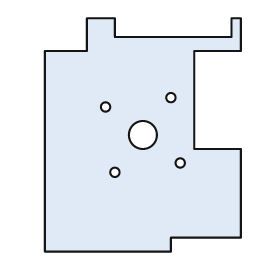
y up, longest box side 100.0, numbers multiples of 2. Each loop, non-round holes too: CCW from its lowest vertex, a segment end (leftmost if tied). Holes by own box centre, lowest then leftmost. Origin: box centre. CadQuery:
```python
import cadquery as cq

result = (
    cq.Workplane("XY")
    .moveTo(-42.0, -50.0)
    .lineTo(12.0, -50.0)
    .lineTo(12.0, -44.0)
    .lineTo(42.0, -44.0)
    .lineTo(42.0, -6.0)
    .lineTo(22.0, -6.0)
    .lineTo(22.0, 36.0)
    .lineTo(42.0, 36.0)
    .lineTo(42.0, 50.0)
    .lineTo(38.0, 50.0)
    .lineTo(38.0, 42.0)
    .lineTo(-12.0, 42.0)
    .lineTo(-12.0, 50.0)
    .lineTo(-24.0, 50.0)
    .lineTo(-24.0, 36.0)
    .lineTo(-42.0, 36.0)
    .close()
    .moveTo(-12.0, -16.0)
    .circle(2.0)
    .moveTo(16.0, -12.0)
    .circle(2.0)
    .moveTo(0.0, 0.0)
    .circle(6.0)
    .moveTo(-16.0, 12.0)
    .circle(2.0)
    .moveTo(12.0, 16.0)
    .circle(2.0)
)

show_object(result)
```